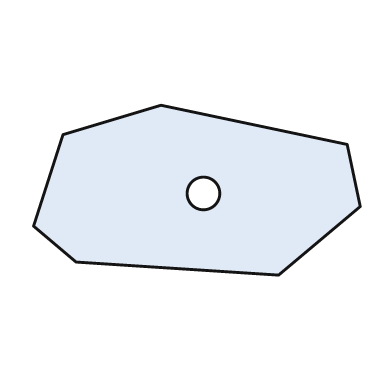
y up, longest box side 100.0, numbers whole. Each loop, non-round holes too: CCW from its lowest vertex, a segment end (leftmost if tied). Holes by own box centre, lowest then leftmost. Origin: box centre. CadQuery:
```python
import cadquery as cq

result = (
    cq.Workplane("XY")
    .moveTo(25.0, -26.0)
    .lineTo(50.0, -5.0)
    .lineTo(46.0, 14.0)
    .lineTo(-11.0, 26.0)
    .lineTo(-41.0, 17.0)
    .lineTo(-50.0, -11.0)
    .lineTo(-37.0, -22.0)
    .close()
    .moveTo(2.0, -1.0)
    .circle(5.0)
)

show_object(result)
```